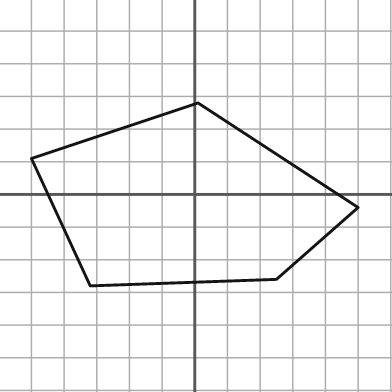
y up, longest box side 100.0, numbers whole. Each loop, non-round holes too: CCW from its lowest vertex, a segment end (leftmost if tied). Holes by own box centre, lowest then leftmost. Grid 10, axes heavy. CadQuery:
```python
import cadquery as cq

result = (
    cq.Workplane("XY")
    .moveTo(-32.0, -28.0)
    .lineTo(25.0, -26.0)
    .lineTo(50.0, -4.0)
    .lineTo(1.0, 28.0)
    .lineTo(-50.0, 11.0)
    .close()
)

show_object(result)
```